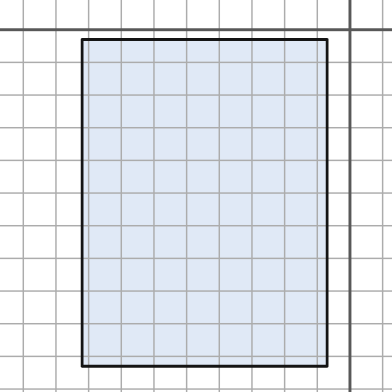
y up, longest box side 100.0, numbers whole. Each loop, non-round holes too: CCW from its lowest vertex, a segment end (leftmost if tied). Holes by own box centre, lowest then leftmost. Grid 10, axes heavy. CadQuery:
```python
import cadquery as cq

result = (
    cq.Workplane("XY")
    .moveTo(-82.0, -103.0)
    .lineTo(-7.0, -103.0)
    .lineTo(-7.0, -3.0)
    .lineTo(-82.0, -3.0)
    .close()
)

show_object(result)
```